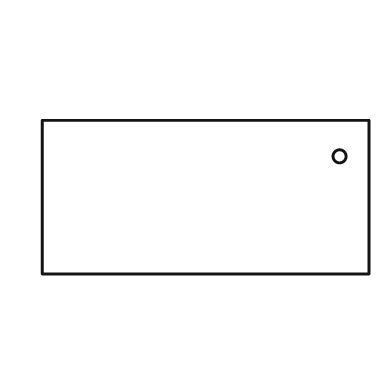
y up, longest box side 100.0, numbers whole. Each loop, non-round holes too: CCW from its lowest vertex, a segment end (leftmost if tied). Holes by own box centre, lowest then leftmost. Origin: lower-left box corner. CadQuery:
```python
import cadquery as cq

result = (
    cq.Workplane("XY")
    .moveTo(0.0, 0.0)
    .lineTo(100.0, 0.0)
    .lineTo(100.0, 47.0)
    .lineTo(0.0, 47.0)
    .close()
    .moveTo(91.0, 36.0)
    .circle(2.0)
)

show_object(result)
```